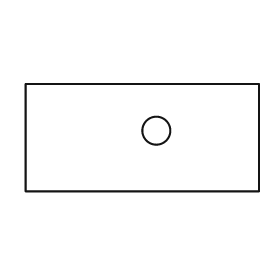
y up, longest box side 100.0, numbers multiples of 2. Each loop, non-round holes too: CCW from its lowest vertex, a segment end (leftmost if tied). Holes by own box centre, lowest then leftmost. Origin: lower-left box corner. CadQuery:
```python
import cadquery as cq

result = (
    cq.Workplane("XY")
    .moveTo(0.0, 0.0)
    .lineTo(100.0, 0.0)
    .lineTo(100.0, 46.0)
    .lineTo(0.0, 46.0)
    .close()
    .moveTo(56.0, 26.0)
    .circle(6.0)
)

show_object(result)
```